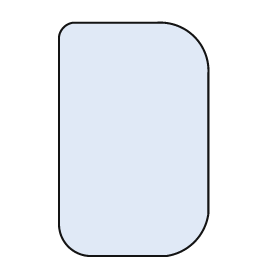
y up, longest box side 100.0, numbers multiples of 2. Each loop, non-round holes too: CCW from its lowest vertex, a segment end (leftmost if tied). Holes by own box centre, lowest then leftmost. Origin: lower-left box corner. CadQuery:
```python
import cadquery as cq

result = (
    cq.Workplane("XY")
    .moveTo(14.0, 0.0)
    .lineTo(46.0, 0.0)
    .threePointArc((58.0, 6.0), (64.0, 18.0))
    .lineTo(64.0, 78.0)
    .threePointArc((58.0, 94.0), (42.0, 100.0))
    .lineTo(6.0, 100.0)
    .threePointArc((2.0, 98.0), (0.0, 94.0))
    .lineTo(0.0, 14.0)
    .threePointArc((4.0, 4.0), (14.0, 0.0))
    .close()
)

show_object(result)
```